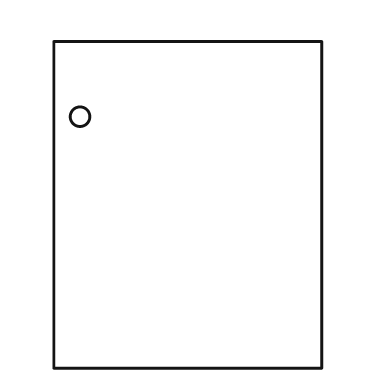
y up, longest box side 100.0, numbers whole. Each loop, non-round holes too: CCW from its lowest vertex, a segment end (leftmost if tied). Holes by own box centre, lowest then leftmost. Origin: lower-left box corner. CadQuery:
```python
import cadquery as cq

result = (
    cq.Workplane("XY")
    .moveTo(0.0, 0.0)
    .lineTo(82.0, 0.0)
    .lineTo(82.0, 100.0)
    .lineTo(0.0, 100.0)
    .close()
    .moveTo(8.0, 77.0)
    .circle(3.0)
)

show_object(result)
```